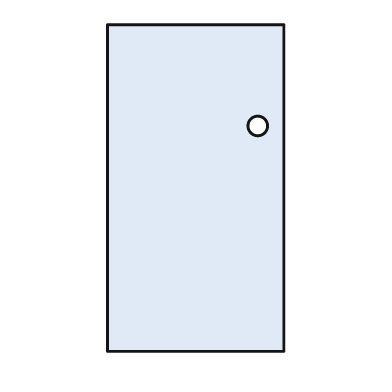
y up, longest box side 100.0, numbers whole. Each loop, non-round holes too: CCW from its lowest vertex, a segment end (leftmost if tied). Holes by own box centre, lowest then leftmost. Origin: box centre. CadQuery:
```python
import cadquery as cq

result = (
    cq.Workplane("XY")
    .moveTo(-27.0, -50.0)
    .lineTo(27.0, -50.0)
    .lineTo(27.0, 50.0)
    .lineTo(-27.0, 50.0)
    .close()
    .moveTo(19.0, 19.0)
    .circle(3.0)
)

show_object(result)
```